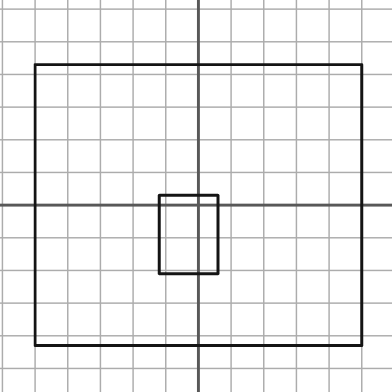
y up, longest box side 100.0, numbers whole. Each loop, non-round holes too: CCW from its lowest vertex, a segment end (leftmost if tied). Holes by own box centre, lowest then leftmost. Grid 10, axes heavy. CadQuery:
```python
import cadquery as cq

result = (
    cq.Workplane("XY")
    .moveTo(-50.0, -43.0)
    .lineTo(50.0, -43.0)
    .lineTo(50.0, 43.0)
    .lineTo(-50.0, 43.0)
    .close()
    .moveTo(-12.0, -21.0)
    .lineTo(6.0, -21.0)
    .lineTo(6.0, 3.0)
    .lineTo(-12.0, 3.0)
    .close()
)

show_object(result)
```